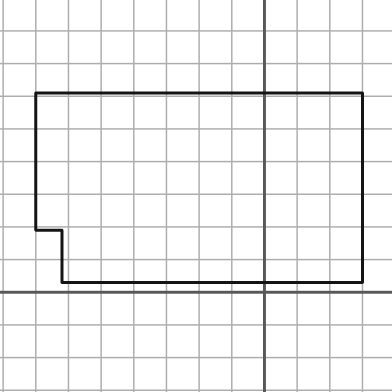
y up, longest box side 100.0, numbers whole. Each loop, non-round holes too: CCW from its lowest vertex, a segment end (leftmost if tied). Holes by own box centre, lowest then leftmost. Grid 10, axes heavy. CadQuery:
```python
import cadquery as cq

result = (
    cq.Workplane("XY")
    .moveTo(-62.0, 3.0)
    .lineTo(30.0, 3.0)
    .lineTo(30.0, 61.0)
    .lineTo(-70.0, 61.0)
    .lineTo(-70.0, 19.0)
    .lineTo(-62.0, 19.0)
    .close()
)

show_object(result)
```